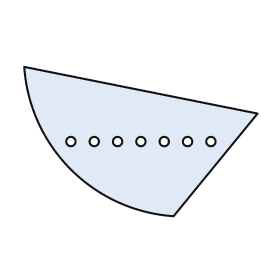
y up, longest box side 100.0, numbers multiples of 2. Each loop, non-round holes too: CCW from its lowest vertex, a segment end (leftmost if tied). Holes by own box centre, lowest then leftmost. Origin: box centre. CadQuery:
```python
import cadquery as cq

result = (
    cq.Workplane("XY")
    .moveTo(14.0, -32.0)
    .lineTo(50.0, 12.0)
    .lineTo(-50.0, 32.0)
    .threePointArc((-30.0, -12.0), (14.0, -32.0))
    .close()
    .moveTo(-30.0, 0.0)
    .circle(2.0)
    .moveTo(-20.0, 0.0)
    .circle(2.0)
    .moveTo(-10.0, 0.0)
    .circle(2.0)
    .moveTo(0.0, 0.0)
    .circle(2.0)
    .moveTo(10.0, 0.0)
    .circle(2.0)
    .moveTo(20.0, 0.0)
    .circle(2.0)
    .moveTo(30.0, 0.0)
    .circle(2.0)
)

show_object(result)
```